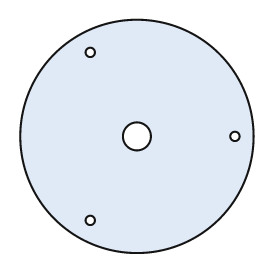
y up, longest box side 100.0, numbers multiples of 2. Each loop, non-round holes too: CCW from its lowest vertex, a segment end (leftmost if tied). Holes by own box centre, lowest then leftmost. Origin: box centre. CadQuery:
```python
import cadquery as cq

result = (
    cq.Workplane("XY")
    .moveTo(0.0, 0.0)
    .circle(50.0)
    .moveTo(-20.0, -36.0)
    .circle(2.0)
    .moveTo(0.0, 0.0)
    .circle(6.0)
    .moveTo(42.0, 0.0)
    .circle(2.0)
    .moveTo(-20.0, 36.0)
    .circle(2.0)
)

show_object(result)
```